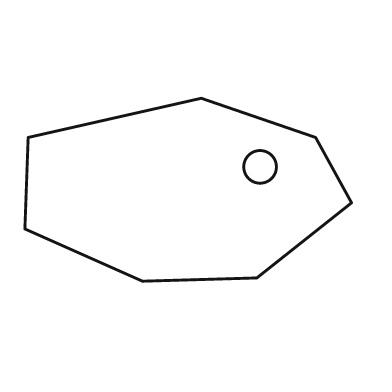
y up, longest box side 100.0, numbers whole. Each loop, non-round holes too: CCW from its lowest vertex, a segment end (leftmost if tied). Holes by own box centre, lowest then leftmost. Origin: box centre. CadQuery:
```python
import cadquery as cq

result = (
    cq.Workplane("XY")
    .moveTo(-14.0, -28.0)
    .lineTo(21.0, -27.0)
    .lineTo(50.0, -4.0)
    .lineTo(39.0, 16.0)
    .lineTo(4.0, 28.0)
    .lineTo(-49.0, 16.0)
    .lineTo(-50.0, -12.0)
    .close()
    .moveTo(22.0, 7.0)
    .circle(5.0)
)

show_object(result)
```